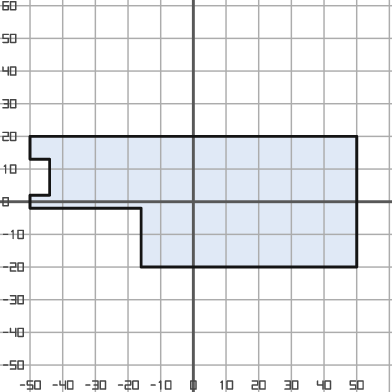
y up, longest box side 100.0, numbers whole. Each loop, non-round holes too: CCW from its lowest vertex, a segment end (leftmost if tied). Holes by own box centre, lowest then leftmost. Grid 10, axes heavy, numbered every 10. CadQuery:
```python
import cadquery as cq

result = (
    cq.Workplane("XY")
    .moveTo(-16.0, -20.0)
    .lineTo(50.0, -20.0)
    .lineTo(50.0, 20.0)
    .lineTo(-50.0, 20.0)
    .lineTo(-50.0, 13.0)
    .lineTo(-44.0, 13.0)
    .lineTo(-44.0, 2.0)
    .lineTo(-50.0, 2.0)
    .lineTo(-50.0, -2.0)
    .lineTo(-16.0, -2.0)
    .close()
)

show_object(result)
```